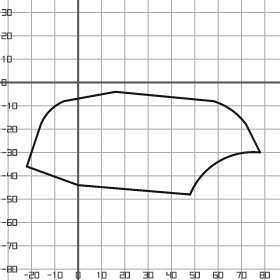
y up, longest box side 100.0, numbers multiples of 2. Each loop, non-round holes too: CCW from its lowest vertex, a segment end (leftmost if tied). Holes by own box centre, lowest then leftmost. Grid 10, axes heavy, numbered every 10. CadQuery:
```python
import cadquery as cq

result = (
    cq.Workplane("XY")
    .moveTo(48.0, -48.0)
    .threePointArc((60.0, -34.0), (78.0, -30.0))
    .lineTo(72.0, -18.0)
    .threePointArc((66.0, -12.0), (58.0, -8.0))
    .lineTo(16.0, -4.0)
    .lineTo(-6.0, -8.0)
    .threePointArc((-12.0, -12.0), (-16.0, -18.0))
    .lineTo(-22.0, -36.0)
    .lineTo(0.0, -44.0)
    .close()
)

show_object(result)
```